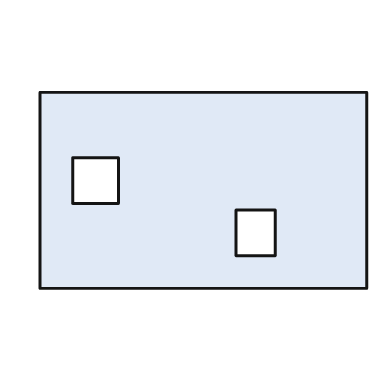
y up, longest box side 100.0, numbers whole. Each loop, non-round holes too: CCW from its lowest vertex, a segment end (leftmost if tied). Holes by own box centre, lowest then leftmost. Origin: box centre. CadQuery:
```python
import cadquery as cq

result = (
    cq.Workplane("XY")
    .moveTo(-50.0, -30.0)
    .lineTo(50.0, -30.0)
    .lineTo(50.0, 30.0)
    .lineTo(-50.0, 30.0)
    .close()
    .moveTo(10.0, -20.0)
    .lineTo(22.0, -20.0)
    .lineTo(22.0, -6.0)
    .lineTo(10.0, -6.0)
    .close()
    .moveTo(-40.0, -4.0)
    .lineTo(-26.0, -4.0)
    .lineTo(-26.0, 10.0)
    .lineTo(-40.0, 10.0)
    .close()
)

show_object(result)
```